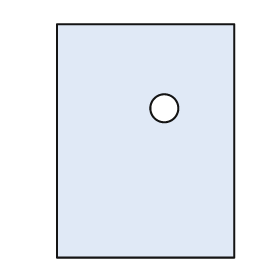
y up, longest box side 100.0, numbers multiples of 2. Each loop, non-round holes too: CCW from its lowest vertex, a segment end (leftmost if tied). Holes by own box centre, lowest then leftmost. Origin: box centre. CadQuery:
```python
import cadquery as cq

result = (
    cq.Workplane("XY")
    .moveTo(-38.0, -50.0)
    .lineTo(38.0, -50.0)
    .lineTo(38.0, 50.0)
    .lineTo(-38.0, 50.0)
    .close()
    .moveTo(8.0, 14.0)
    .circle(6.0)
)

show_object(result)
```